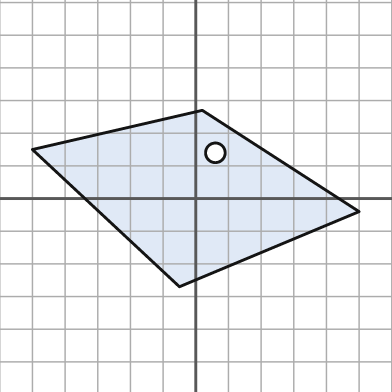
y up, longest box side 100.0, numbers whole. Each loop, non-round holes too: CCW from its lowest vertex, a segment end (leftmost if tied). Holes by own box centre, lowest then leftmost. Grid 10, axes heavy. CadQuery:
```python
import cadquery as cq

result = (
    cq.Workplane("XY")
    .moveTo(-5.0, -27.0)
    .lineTo(50.0, -4.0)
    .lineTo(2.0, 27.0)
    .lineTo(-50.0, 15.0)
    .close()
    .moveTo(6.0, 14.0)
    .circle(3.0)
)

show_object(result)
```